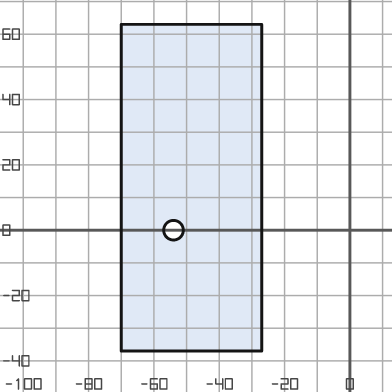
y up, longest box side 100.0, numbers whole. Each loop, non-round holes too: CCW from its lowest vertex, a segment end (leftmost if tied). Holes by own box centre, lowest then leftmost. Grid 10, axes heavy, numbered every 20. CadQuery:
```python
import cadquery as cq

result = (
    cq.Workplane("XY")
    .moveTo(-70.0, -37.0)
    .lineTo(-27.0, -37.0)
    .lineTo(-27.0, 63.0)
    .lineTo(-70.0, 63.0)
    .close()
    .moveTo(-54.0, 0.0)
    .circle(3.0)
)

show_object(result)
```